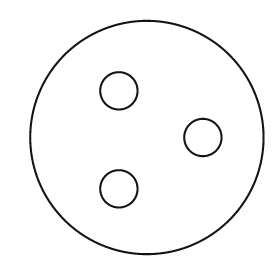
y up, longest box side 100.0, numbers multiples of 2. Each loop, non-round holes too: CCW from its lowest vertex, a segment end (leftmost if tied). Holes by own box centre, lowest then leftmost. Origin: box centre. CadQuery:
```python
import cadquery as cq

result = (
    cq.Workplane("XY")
    .moveTo(0.0, 0.0)
    .circle(50.0)
    .moveTo(-12.0, -22.0)
    .circle(8.0)
    .moveTo(24.0, 0.0)
    .circle(8.0)
    .moveTo(-12.0, 20.0)
    .circle(8.0)
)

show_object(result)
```